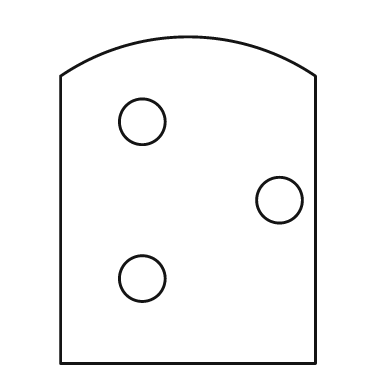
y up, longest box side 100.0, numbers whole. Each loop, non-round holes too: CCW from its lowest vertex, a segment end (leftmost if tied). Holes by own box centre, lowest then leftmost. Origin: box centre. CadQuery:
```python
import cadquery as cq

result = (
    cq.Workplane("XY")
    .moveTo(-39.0, -50.0)
    .lineTo(39.0, -50.0)
    .lineTo(39.0, 38.0)
    .threePointArc((0.0, 50.0), (-39.0, 38.0))
    .close()
    .moveTo(-14.0, -24.0)
    .circle(7.0)
    .moveTo(28.0, 0.0)
    .circle(7.0)
    .moveTo(-14.0, 24.0)
    .circle(7.0)
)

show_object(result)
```